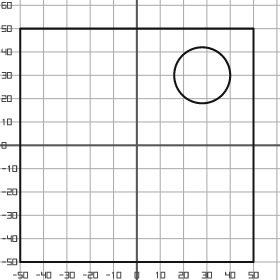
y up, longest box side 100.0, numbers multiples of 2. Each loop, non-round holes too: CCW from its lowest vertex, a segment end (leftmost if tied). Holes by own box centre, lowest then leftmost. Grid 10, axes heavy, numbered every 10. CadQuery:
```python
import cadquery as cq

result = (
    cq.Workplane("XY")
    .moveTo(-50.0, -50.0)
    .lineTo(50.0, -50.0)
    .lineTo(50.0, 50.0)
    .lineTo(-50.0, 50.0)
    .close()
    .moveTo(28.0, 30.0)
    .circle(12.0)
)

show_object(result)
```